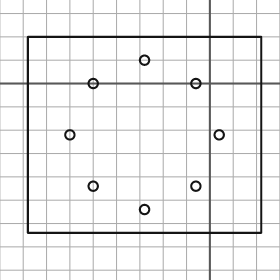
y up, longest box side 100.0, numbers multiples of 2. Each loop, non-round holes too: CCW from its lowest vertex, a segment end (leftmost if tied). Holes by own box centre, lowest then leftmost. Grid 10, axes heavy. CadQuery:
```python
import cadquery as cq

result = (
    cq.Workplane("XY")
    .moveTo(-78.0, -64.0)
    .lineTo(22.0, -64.0)
    .lineTo(22.0, 20.0)
    .lineTo(-78.0, 20.0)
    .close()
    .moveTo(-28.0, -54.0)
    .circle(2.0)
    .moveTo(-50.0, -44.0)
    .circle(2.0)
    .moveTo(-6.0, -44.0)
    .circle(2.0)
    .moveTo(-60.0, -22.0)
    .circle(2.0)
    .moveTo(4.0, -22.0)
    .circle(2.0)
    .moveTo(-50.0, 0.0)
    .circle(2.0)
    .moveTo(-6.0, 0.0)
    .circle(2.0)
    .moveTo(-28.0, 10.0)
    .circle(2.0)
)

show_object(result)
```